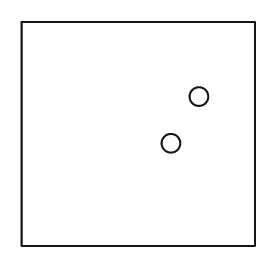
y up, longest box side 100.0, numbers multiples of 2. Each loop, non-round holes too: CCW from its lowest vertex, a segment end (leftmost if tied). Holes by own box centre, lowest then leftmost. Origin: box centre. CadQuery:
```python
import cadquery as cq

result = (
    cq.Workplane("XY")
    .moveTo(-50.0, -48.0)
    .lineTo(50.0, -48.0)
    .lineTo(50.0, 48.0)
    .lineTo(-50.0, 48.0)
    .close()
    .moveTo(14.0, -4.0)
    .circle(4.0)
    .moveTo(26.0, 16.0)
    .circle(4.0)
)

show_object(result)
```